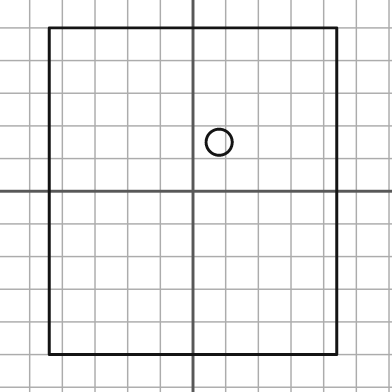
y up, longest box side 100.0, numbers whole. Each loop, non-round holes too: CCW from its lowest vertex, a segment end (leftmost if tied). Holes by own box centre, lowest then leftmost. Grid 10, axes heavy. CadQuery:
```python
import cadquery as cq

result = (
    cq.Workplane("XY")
    .moveTo(-44.0, -50.0)
    .lineTo(44.0, -50.0)
    .lineTo(44.0, 50.0)
    .lineTo(-44.0, 50.0)
    .close()
    .moveTo(8.0, 15.0)
    .circle(4.0)
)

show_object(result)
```